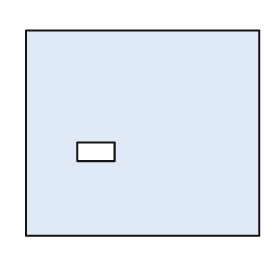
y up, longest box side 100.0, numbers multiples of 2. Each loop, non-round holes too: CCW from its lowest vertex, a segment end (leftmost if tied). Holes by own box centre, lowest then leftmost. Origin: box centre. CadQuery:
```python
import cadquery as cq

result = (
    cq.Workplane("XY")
    .moveTo(-50.0, -44.0)
    .lineTo(50.0, -44.0)
    .lineTo(50.0, 44.0)
    .lineTo(-50.0, 44.0)
    .close()
    .moveTo(-28.0, -12.0)
    .lineTo(-12.0, -12.0)
    .lineTo(-12.0, -4.0)
    .lineTo(-28.0, -4.0)
    .close()
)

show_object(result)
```